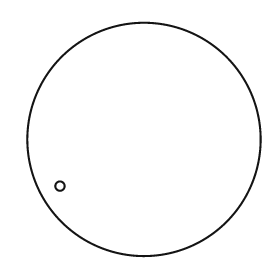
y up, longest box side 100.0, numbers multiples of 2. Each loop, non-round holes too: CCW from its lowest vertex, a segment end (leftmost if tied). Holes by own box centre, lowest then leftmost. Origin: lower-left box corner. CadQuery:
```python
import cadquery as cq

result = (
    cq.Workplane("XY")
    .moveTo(50.0, 50.0)
    .circle(50.0)
    .moveTo(14.0, 30.0)
    .circle(2.0)
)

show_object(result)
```